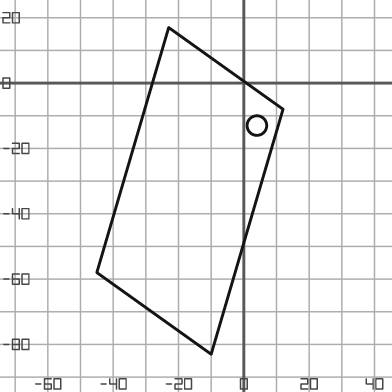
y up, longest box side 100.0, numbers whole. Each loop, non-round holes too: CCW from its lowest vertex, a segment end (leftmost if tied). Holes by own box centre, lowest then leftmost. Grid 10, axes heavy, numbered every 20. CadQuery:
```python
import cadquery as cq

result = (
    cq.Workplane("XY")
    .moveTo(-10.0, -83.0)
    .lineTo(12.0, -8.0)
    .lineTo(-23.0, 17.0)
    .lineTo(-45.0, -58.0)
    .close()
    .moveTo(4.0, -13.0)
    .circle(3.0)
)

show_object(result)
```